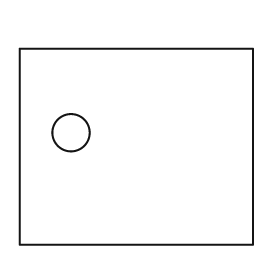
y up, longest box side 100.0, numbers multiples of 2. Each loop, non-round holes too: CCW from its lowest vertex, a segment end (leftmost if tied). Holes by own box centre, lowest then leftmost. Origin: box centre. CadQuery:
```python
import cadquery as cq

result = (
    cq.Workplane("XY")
    .moveTo(-50.0, -42.0)
    .lineTo(50.0, -42.0)
    .lineTo(50.0, 42.0)
    .lineTo(-50.0, 42.0)
    .close()
    .moveTo(-28.0, 6.0)
    .circle(8.0)
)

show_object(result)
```